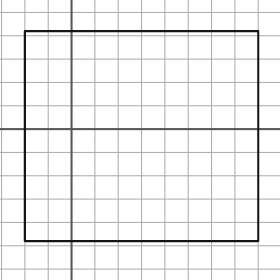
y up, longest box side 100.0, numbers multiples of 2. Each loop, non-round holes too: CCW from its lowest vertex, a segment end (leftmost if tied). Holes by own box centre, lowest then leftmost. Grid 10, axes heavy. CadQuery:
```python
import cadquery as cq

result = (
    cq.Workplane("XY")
    .moveTo(-20.0, -48.0)
    .lineTo(80.0, -48.0)
    .lineTo(80.0, 42.0)
    .lineTo(-20.0, 42.0)
    .close()
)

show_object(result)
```